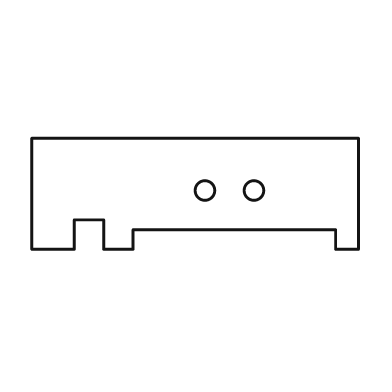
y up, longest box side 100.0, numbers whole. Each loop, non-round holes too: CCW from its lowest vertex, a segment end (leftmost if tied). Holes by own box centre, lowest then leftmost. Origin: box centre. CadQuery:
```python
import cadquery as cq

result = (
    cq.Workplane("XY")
    .moveTo(-50.0, -17.0)
    .lineTo(-37.0, -17.0)
    .lineTo(-37.0, -8.0)
    .lineTo(-28.0, -8.0)
    .lineTo(-28.0, -17.0)
    .lineTo(-19.0, -17.0)
    .lineTo(-19.0, -11.0)
    .lineTo(43.0, -11.0)
    .lineTo(43.0, -17.0)
    .lineTo(50.0, -17.0)
    .lineTo(50.0, 17.0)
    .lineTo(-50.0, 17.0)
    .close()
    .moveTo(3.0, 1.0)
    .circle(3.0)
    .moveTo(18.0, 1.0)
    .circle(3.0)
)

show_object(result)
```